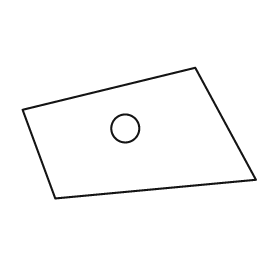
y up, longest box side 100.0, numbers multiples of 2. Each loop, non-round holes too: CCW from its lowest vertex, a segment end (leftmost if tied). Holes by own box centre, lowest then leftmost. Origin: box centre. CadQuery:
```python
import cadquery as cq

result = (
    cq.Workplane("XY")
    .moveTo(-36.0, -28.0)
    .lineTo(50.0, -20.0)
    .lineTo(24.0, 28.0)
    .lineTo(-50.0, 10.0)
    .close()
    .moveTo(-6.0, 2.0)
    .circle(6.0)
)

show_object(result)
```